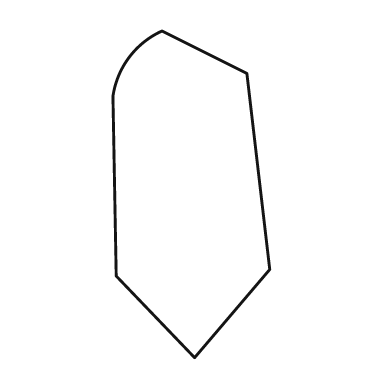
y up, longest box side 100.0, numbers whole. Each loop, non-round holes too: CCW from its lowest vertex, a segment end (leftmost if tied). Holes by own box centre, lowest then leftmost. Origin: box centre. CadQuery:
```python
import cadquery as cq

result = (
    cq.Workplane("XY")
    .moveTo(1.0, -50.0)
    .lineTo(24.0, -23.0)
    .lineTo(17.0, 37.0)
    .lineTo(-9.0, 50.0)
    .threePointArc((-19.0, 42.0), (-24.0, 30.0))
    .lineTo(-23.0, -25.0)
    .close()
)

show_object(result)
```